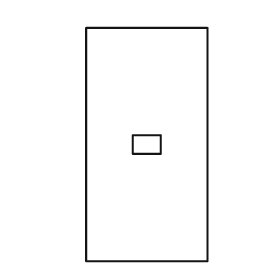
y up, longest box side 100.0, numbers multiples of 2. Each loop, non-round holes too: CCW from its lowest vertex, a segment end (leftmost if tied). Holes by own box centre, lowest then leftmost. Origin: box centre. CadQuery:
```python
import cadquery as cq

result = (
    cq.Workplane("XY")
    .moveTo(-26.0, -50.0)
    .lineTo(26.0, -50.0)
    .lineTo(26.0, 50.0)
    .lineTo(-26.0, 50.0)
    .close()
    .moveTo(-6.0, -4.0)
    .lineTo(6.0, -4.0)
    .lineTo(6.0, 4.0)
    .lineTo(-6.0, 4.0)
    .close()
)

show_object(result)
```